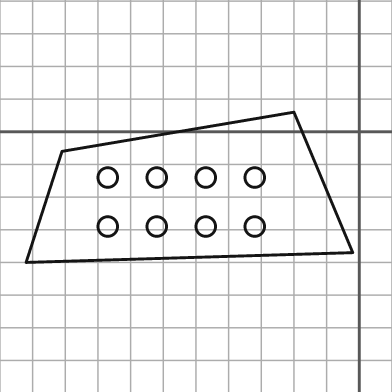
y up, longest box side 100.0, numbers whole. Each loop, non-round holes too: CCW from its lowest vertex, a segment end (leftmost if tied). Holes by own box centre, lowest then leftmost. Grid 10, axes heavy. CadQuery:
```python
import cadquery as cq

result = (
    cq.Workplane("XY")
    .moveTo(-102.0, -40.0)
    .lineTo(-2.0, -37.0)
    .lineTo(-20.0, 6.0)
    .lineTo(-91.0, -6.0)
    .close()
    .moveTo(-77.0, -29.0)
    .circle(3.0)
    .moveTo(-62.0, -29.0)
    .circle(3.0)
    .moveTo(-47.0, -29.0)
    .circle(3.0)
    .moveTo(-32.0, -29.0)
    .circle(3.0)
    .moveTo(-77.0, -14.0)
    .circle(3.0)
    .moveTo(-62.0, -14.0)
    .circle(3.0)
    .moveTo(-47.0, -14.0)
    .circle(3.0)
    .moveTo(-32.0, -14.0)
    .circle(3.0)
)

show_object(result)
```